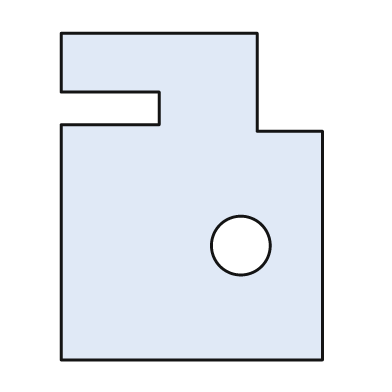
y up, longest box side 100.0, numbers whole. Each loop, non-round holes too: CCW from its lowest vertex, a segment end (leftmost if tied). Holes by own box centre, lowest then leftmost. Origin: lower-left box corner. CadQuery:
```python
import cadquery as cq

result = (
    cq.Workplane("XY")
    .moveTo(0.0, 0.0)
    .lineTo(80.0, 0.0)
    .lineTo(80.0, 70.0)
    .lineTo(60.0, 70.0)
    .lineTo(60.0, 100.0)
    .lineTo(0.0, 100.0)
    .lineTo(0.0, 82.0)
    .lineTo(30.0, 82.0)
    .lineTo(30.0, 72.0)
    .lineTo(0.0, 72.0)
    .close()
    .moveTo(55.0, 35.0)
    .circle(9.0)
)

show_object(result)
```